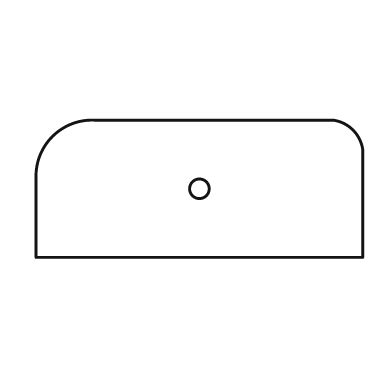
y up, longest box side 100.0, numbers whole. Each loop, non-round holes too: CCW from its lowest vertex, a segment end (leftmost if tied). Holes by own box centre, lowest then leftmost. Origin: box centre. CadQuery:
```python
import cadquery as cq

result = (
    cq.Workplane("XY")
    .moveTo(-50.0, -21.0)
    .lineTo(50.0, -21.0)
    .lineTo(50.0, 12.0)
    .threePointArc((47.0, 18.0), (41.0, 21.0))
    .lineTo(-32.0, 21.0)
    .threePointArc((-45.0, 16.0), (-50.0, 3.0))
    .close()
    .moveTo(0.0, 0.0)
    .circle(3.0)
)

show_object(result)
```